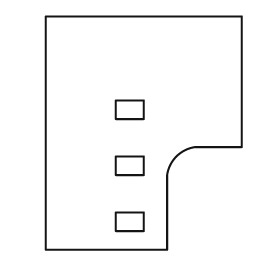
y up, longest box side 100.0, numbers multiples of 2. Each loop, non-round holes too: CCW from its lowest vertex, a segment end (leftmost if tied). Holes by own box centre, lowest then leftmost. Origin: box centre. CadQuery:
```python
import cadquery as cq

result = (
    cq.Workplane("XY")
    .moveTo(-42.0, -50.0)
    .lineTo(10.0, -50.0)
    .lineTo(10.0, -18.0)
    .threePointArc((14.0, -10.0), (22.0, -6.0))
    .lineTo(42.0, -6.0)
    .lineTo(42.0, 50.0)
    .lineTo(-42.0, 50.0)
    .close()
    .moveTo(-12.0, -42.0)
    .lineTo(0.0, -42.0)
    .lineTo(0.0, -34.0)
    .lineTo(-12.0, -34.0)
    .close()
    .moveTo(-12.0, -18.0)
    .lineTo(0.0, -18.0)
    .lineTo(0.0, -10.0)
    .lineTo(-12.0, -10.0)
    .close()
    .moveTo(-12.0, 6.0)
    .lineTo(0.0, 6.0)
    .lineTo(0.0, 14.0)
    .lineTo(-12.0, 14.0)
    .close()
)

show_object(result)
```